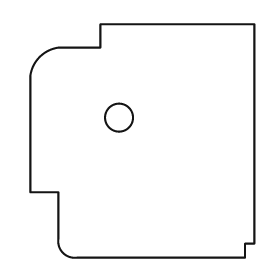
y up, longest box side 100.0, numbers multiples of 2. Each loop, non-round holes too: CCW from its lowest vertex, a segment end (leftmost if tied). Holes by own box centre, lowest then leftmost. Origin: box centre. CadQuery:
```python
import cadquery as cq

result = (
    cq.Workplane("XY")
    .moveTo(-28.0, -50.0)
    .lineTo(44.0, -50.0)
    .lineTo(44.0, -44.0)
    .lineTo(48.0, -44.0)
    .lineTo(48.0, 50.0)
    .lineTo(-18.0, 50.0)
    .lineTo(-18.0, 40.0)
    .lineTo(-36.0, 40.0)
    .threePointArc((-44.0, 36.0), (-48.0, 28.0))
    .lineTo(-48.0, -22.0)
    .lineTo(-36.0, -22.0)
    .lineTo(-36.0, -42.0)
    .threePointArc((-34.0, -48.0), (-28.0, -50.0))
    .close()
    .moveTo(-10.0, 10.0)
    .circle(6.0)
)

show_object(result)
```